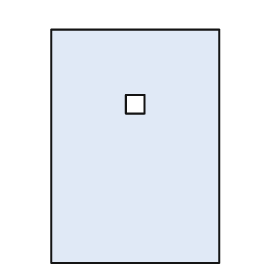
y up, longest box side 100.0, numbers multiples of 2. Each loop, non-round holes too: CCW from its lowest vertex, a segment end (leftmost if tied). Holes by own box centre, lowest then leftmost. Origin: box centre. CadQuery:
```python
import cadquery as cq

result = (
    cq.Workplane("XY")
    .moveTo(-36.0, -50.0)
    .lineTo(36.0, -50.0)
    .lineTo(36.0, 50.0)
    .lineTo(-36.0, 50.0)
    .close()
    .moveTo(-4.0, 14.0)
    .lineTo(4.0, 14.0)
    .lineTo(4.0, 22.0)
    .lineTo(-4.0, 22.0)
    .close()
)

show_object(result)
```